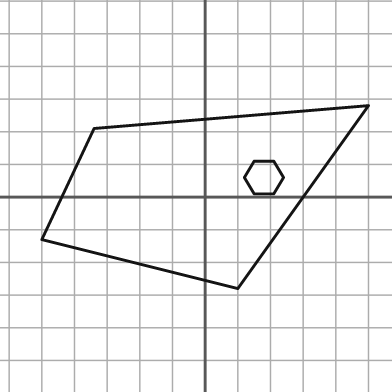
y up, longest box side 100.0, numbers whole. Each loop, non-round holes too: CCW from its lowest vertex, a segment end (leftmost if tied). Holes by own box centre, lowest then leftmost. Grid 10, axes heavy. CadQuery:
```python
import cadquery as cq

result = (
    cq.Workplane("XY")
    .moveTo(10.0, -28.0)
    .lineTo(50.0, 28.0)
    .lineTo(-34.0, 21.0)
    .lineTo(-50.0, -13.0)
    .close()
    .moveTo(15.0, 1.0)
    .lineTo(21.0, 1.0)
    .lineTo(24.0, 6.0)
    .lineTo(21.0, 11.0)
    .lineTo(15.0, 11.0)
    .lineTo(12.0, 6.0)
    .close()
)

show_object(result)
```